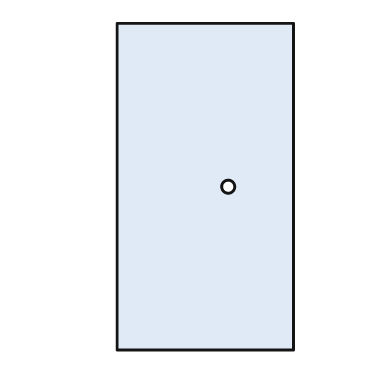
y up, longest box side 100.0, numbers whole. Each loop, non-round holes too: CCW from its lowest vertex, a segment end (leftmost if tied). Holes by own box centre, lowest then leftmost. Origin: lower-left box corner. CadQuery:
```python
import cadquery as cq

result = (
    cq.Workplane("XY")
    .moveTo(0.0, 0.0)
    .lineTo(54.0, 0.0)
    .lineTo(54.0, 100.0)
    .lineTo(0.0, 100.0)
    .close()
    .moveTo(34.0, 50.0)
    .circle(2.0)
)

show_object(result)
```